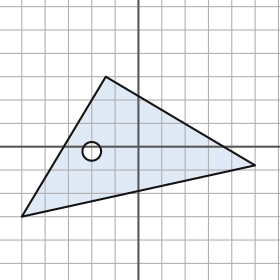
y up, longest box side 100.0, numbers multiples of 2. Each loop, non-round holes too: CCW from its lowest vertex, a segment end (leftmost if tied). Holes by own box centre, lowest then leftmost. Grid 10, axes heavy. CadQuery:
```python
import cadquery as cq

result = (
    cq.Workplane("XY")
    .moveTo(-50.0, -30.0)
    .lineTo(50.0, -8.0)
    .lineTo(-14.0, 30.0)
    .close()
    .moveTo(-20.0, -2.0)
    .circle(4.0)
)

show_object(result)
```